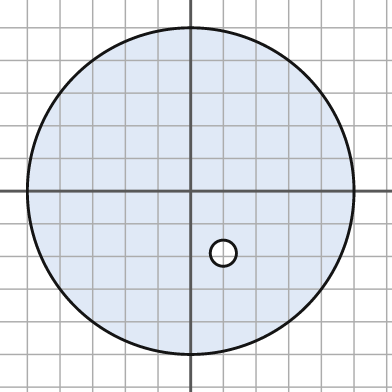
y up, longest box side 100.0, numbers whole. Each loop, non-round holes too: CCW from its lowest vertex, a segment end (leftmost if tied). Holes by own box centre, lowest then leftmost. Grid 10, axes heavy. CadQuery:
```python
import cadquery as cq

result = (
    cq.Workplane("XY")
    .moveTo(0.0, 0.0)
    .circle(50.0)
    .moveTo(10.0, -19.0)
    .circle(4.0)
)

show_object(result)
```